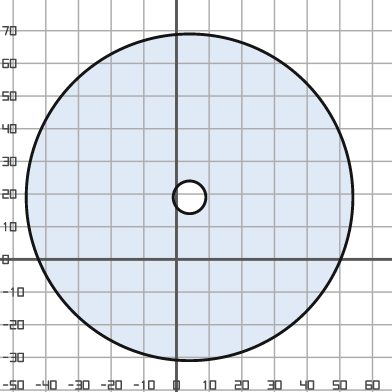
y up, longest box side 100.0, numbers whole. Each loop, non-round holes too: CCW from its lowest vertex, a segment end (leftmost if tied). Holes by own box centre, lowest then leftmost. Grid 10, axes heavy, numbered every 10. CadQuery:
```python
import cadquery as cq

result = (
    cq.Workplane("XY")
    .moveTo(4.0, 19.0)
    .circle(50.0)
    .moveTo(4.0, 19.0)
    .circle(5.0)
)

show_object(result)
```